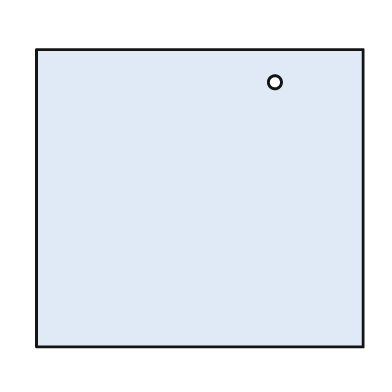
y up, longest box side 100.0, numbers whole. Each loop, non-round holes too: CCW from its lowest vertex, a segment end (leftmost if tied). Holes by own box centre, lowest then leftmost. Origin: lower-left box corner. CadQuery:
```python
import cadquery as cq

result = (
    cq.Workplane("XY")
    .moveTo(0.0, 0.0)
    .lineTo(100.0, 0.0)
    .lineTo(100.0, 91.0)
    .lineTo(0.0, 91.0)
    .close()
    .moveTo(73.0, 81.0)
    .circle(2.0)
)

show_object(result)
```